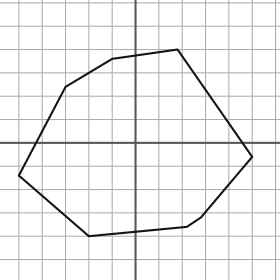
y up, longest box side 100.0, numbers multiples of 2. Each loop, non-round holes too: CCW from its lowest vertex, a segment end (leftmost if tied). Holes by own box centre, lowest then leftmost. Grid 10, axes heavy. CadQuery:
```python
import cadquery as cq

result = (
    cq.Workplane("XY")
    .moveTo(-20.0, -40.0)
    .lineTo(22.0, -36.0)
    .lineTo(28.0, -32.0)
    .lineTo(50.0, -6.0)
    .lineTo(18.0, 40.0)
    .lineTo(-10.0, 36.0)
    .lineTo(-30.0, 24.0)
    .lineTo(-50.0, -14.0)
    .close()
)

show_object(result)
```